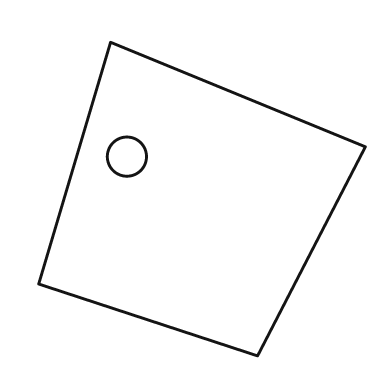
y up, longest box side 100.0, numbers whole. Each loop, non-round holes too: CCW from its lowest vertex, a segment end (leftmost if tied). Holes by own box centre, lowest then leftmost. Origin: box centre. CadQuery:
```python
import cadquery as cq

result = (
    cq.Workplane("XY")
    .moveTo(17.0, -48.0)
    .lineTo(50.0, 16.0)
    .lineTo(-28.0, 48.0)
    .lineTo(-50.0, -26.0)
    .close()
    .moveTo(-23.0, 13.0)
    .circle(6.0)
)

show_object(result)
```